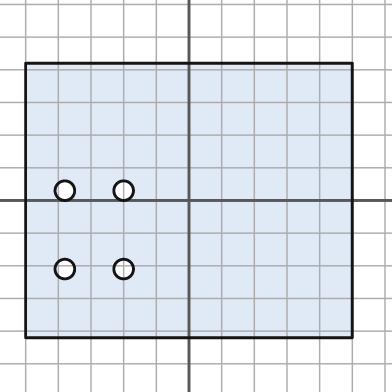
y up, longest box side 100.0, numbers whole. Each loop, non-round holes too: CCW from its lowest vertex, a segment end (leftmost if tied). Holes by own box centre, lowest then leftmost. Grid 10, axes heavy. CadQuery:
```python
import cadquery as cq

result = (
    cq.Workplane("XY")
    .moveTo(-50.0, -42.0)
    .lineTo(50.0, -42.0)
    .lineTo(50.0, 42.0)
    .lineTo(-50.0, 42.0)
    .close()
    .moveTo(-38.0, -21.0)
    .circle(3.0)
    .moveTo(-20.0, -21.0)
    .circle(3.0)
    .moveTo(-38.0, 3.0)
    .circle(3.0)
    .moveTo(-20.0, 3.0)
    .circle(3.0)
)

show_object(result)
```